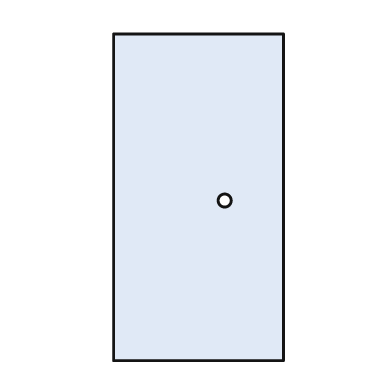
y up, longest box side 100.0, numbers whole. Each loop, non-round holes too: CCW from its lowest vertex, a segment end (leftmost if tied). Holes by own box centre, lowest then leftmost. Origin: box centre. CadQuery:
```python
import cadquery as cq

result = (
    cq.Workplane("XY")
    .moveTo(-26.0, -50.0)
    .lineTo(26.0, -50.0)
    .lineTo(26.0, 50.0)
    .lineTo(-26.0, 50.0)
    .close()
    .moveTo(8.0, -1.0)
    .circle(2.0)
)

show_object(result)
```